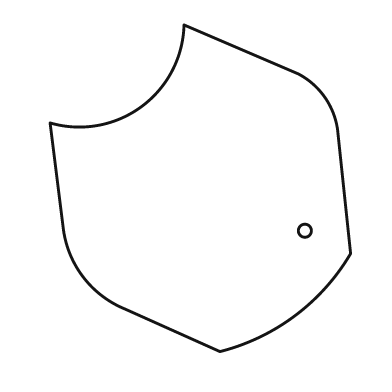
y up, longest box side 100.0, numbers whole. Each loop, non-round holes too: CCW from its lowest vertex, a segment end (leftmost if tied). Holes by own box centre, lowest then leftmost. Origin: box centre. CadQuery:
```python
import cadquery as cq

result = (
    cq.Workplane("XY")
    .moveTo(6.0, -50.0)
    .threePointArc((29.0, -39.0), (46.0, -20.0))
    .lineTo(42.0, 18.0)
    .threePointArc((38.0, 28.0), (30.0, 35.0))
    .lineTo(-5.0, 50.0)
    .threePointArc((-18.0, 25.0), (-46.0, 20.0))
    .lineTo(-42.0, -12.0)
    .threePointArc((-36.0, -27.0), (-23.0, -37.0))
    .close()
    .moveTo(32.0, -13.0)
    .circle(2.0)
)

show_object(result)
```